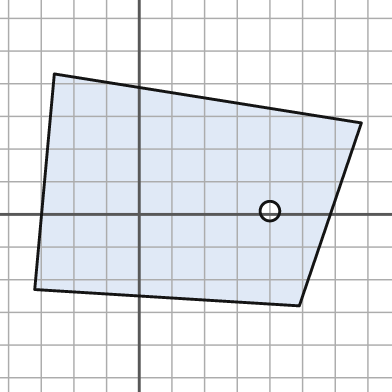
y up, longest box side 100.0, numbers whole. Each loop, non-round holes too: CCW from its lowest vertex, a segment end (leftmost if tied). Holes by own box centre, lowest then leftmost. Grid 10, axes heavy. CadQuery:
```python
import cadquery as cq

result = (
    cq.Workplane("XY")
    .moveTo(49.0, -28.0)
    .lineTo(68.0, 28.0)
    .lineTo(-26.0, 43.0)
    .lineTo(-32.0, -23.0)
    .close()
    .moveTo(40.0, 1.0)
    .circle(3.0)
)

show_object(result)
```